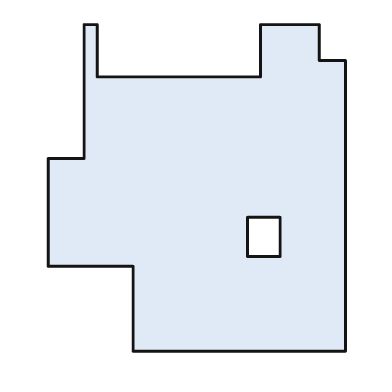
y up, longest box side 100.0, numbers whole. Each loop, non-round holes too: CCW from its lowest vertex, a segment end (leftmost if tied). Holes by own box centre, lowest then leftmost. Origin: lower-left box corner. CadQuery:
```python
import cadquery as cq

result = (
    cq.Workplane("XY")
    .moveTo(26.0, 0.0)
    .lineTo(91.0, 0.0)
    .lineTo(91.0, 89.0)
    .lineTo(83.0, 89.0)
    .lineTo(83.0, 100.0)
    .lineTo(65.0, 100.0)
    .lineTo(65.0, 84.0)
    .lineTo(15.0, 84.0)
    .lineTo(15.0, 100.0)
    .lineTo(11.0, 100.0)
    .lineTo(11.0, 59.0)
    .lineTo(0.0, 59.0)
    .lineTo(0.0, 26.0)
    .lineTo(26.0, 26.0)
    .close()
    .moveTo(61.0, 29.0)
    .lineTo(71.0, 29.0)
    .lineTo(71.0, 41.0)
    .lineTo(61.0, 41.0)
    .close()
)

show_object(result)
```